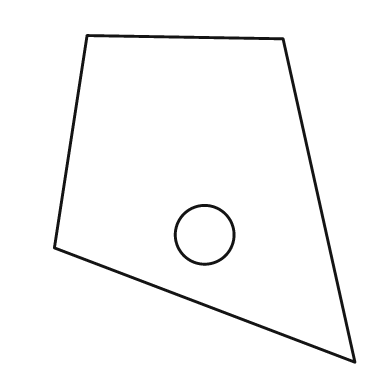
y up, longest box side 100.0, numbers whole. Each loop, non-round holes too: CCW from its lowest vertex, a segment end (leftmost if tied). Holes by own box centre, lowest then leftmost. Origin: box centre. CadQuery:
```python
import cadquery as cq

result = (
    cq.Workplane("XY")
    .moveTo(46.0, -50.0)
    .lineTo(24.0, 49.0)
    .lineTo(-36.0, 50.0)
    .lineTo(-46.0, -15.0)
    .close()
    .moveTo(0.0, -11.0)
    .circle(9.0)
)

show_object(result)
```